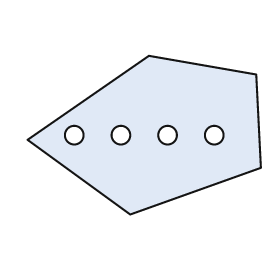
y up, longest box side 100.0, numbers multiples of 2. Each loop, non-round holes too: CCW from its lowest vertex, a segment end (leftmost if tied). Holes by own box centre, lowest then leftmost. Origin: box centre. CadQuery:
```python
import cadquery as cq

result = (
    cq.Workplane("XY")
    .moveTo(-6.0, -34.0)
    .lineTo(50.0, -14.0)
    .lineTo(48.0, 26.0)
    .lineTo(2.0, 34.0)
    .lineTo(-50.0, -2.0)
    .close()
    .moveTo(-30.0, 0.0)
    .circle(4.0)
    .moveTo(-10.0, 0.0)
    .circle(4.0)
    .moveTo(10.0, 0.0)
    .circle(4.0)
    .moveTo(30.0, 0.0)
    .circle(4.0)
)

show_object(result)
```